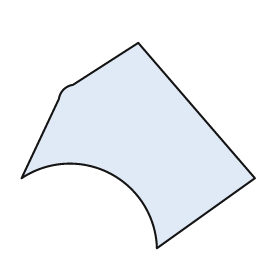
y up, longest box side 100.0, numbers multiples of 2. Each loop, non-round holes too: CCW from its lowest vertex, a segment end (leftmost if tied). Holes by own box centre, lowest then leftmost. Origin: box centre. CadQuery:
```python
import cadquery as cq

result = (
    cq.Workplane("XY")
    .moveTo(8.0, -44.0)
    .lineTo(50.0, -14.0)
    .lineTo(0.0, 44.0)
    .lineTo(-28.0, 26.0)
    .threePointArc((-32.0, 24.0), (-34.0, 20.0))
    .lineTo(-50.0, -14.0)
    .threePointArc((-12.0, -12.0), (8.0, -44.0))
    .close()
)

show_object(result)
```